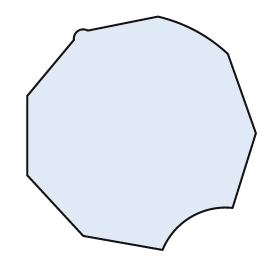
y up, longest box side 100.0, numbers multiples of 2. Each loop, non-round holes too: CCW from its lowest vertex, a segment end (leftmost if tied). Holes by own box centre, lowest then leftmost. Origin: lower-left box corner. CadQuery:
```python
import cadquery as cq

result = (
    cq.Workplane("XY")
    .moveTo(58.0, 0.0)
    .threePointArc((70.0, 14.0), (88.0, 18.0))
    .lineTo(98.0, 50.0)
    .lineTo(86.0, 84.0)
    .threePointArc((72.0, 94.0), (56.0, 100.0))
    .lineTo(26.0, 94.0)
    .threePointArc((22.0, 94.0), (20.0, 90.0))
    .lineTo(0.0, 66.0)
    .lineTo(0.0, 32.0)
    .lineTo(24.0, 6.0)
    .close()
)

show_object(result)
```